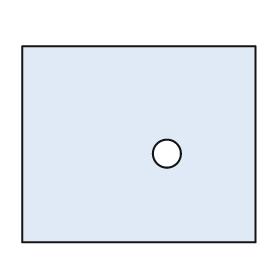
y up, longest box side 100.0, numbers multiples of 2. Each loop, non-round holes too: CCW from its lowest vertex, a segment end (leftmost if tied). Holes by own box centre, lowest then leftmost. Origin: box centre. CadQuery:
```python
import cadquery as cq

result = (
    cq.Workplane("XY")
    .moveTo(-50.0, -42.0)
    .lineTo(50.0, -42.0)
    .lineTo(50.0, 42.0)
    .lineTo(-50.0, 42.0)
    .close()
    .moveTo(12.0, -4.0)
    .circle(6.0)
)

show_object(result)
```